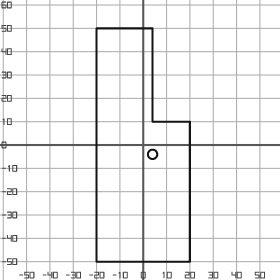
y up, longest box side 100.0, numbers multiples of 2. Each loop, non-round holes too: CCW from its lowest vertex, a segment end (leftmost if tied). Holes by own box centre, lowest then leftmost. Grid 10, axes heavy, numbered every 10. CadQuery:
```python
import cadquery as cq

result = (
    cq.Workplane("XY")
    .moveTo(-20.0, -50.0)
    .lineTo(20.0, -50.0)
    .lineTo(20.0, 10.0)
    .lineTo(4.0, 10.0)
    .lineTo(4.0, 50.0)
    .lineTo(-20.0, 50.0)
    .close()
    .moveTo(4.0, -4.0)
    .circle(2.0)
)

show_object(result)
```